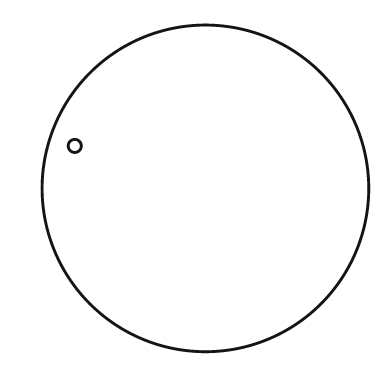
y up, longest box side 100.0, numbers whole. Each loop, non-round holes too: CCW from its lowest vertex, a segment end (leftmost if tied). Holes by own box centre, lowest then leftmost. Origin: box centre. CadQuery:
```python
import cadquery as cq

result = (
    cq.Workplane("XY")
    .moveTo(0.0, 0.0)
    .circle(50.0)
    .moveTo(-40.0, 13.0)
    .circle(2.0)
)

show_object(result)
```